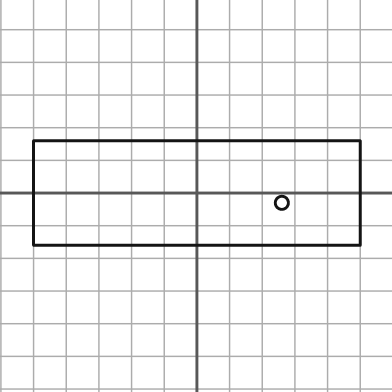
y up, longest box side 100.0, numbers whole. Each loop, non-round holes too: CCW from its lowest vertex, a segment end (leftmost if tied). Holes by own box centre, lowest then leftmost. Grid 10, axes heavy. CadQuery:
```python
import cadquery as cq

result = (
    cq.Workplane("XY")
    .moveTo(-50.0, -16.0)
    .lineTo(50.0, -16.0)
    .lineTo(50.0, 16.0)
    .lineTo(-50.0, 16.0)
    .close()
    .moveTo(26.0, -3.0)
    .circle(2.0)
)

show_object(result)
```